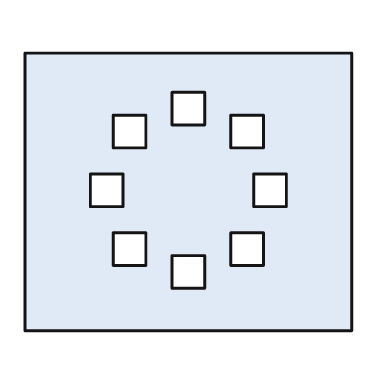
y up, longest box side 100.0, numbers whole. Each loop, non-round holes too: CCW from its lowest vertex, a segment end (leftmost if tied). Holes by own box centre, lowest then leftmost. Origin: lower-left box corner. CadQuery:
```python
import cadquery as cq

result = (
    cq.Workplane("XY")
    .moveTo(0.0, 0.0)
    .lineTo(100.0, 0.0)
    .lineTo(100.0, 85.0)
    .lineTo(0.0, 85.0)
    .close()
    .moveTo(45.0, 13.0)
    .lineTo(55.0, 13.0)
    .lineTo(55.0, 23.0)
    .lineTo(45.0, 23.0)
    .close()
    .moveTo(27.0, 20.0)
    .lineTo(37.0, 20.0)
    .lineTo(37.0, 30.0)
    .lineTo(27.0, 30.0)
    .close()
    .moveTo(63.0, 20.0)
    .lineTo(73.0, 20.0)
    .lineTo(73.0, 30.0)
    .lineTo(63.0, 30.0)
    .close()
    .moveTo(20.0, 38.0)
    .lineTo(30.0, 38.0)
    .lineTo(30.0, 48.0)
    .lineTo(20.0, 48.0)
    .close()
    .moveTo(70.0, 38.0)
    .lineTo(80.0, 38.0)
    .lineTo(80.0, 48.0)
    .lineTo(70.0, 48.0)
    .close()
    .moveTo(27.0, 56.0)
    .lineTo(37.0, 56.0)
    .lineTo(37.0, 66.0)
    .lineTo(27.0, 66.0)
    .close()
    .moveTo(63.0, 56.0)
    .lineTo(73.0, 56.0)
    .lineTo(73.0, 66.0)
    .lineTo(63.0, 66.0)
    .close()
    .moveTo(45.0, 63.0)
    .lineTo(55.0, 63.0)
    .lineTo(55.0, 73.0)
    .lineTo(45.0, 73.0)
    .close()
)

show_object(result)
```